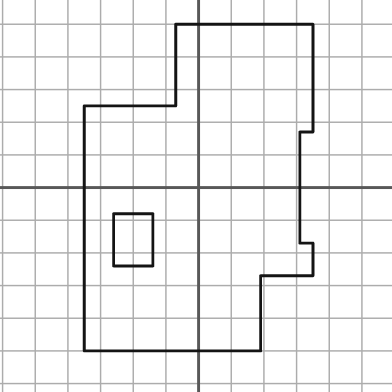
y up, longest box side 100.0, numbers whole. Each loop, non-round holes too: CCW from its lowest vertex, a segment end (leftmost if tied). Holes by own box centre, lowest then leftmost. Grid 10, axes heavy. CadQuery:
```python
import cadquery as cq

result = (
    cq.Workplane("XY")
    .moveTo(-35.0, -50.0)
    .lineTo(19.0, -50.0)
    .lineTo(19.0, -27.0)
    .lineTo(35.0, -27.0)
    .lineTo(35.0, -17.0)
    .lineTo(31.0, -17.0)
    .lineTo(31.0, 17.0)
    .lineTo(35.0, 17.0)
    .lineTo(35.0, 50.0)
    .lineTo(-7.0, 50.0)
    .lineTo(-7.0, 25.0)
    .lineTo(-35.0, 25.0)
    .close()
    .moveTo(-26.0, -24.0)
    .lineTo(-14.0, -24.0)
    .lineTo(-14.0, -8.0)
    .lineTo(-26.0, -8.0)
    .close()
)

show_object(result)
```